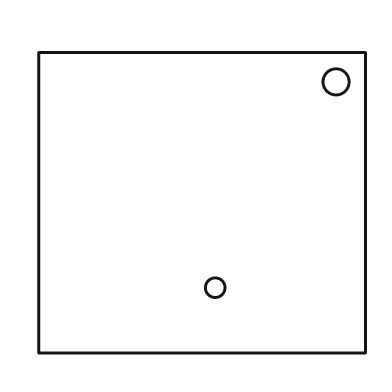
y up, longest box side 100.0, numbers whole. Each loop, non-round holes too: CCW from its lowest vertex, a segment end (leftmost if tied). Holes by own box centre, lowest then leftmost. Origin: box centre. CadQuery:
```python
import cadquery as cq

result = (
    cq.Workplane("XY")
    .moveTo(-50.0, -46.0)
    .lineTo(50.0, -46.0)
    .lineTo(50.0, 46.0)
    .lineTo(-50.0, 46.0)
    .close()
    .moveTo(4.0, -26.0)
    .circle(3.0)
    .moveTo(41.0, 37.0)
    .circle(4.0)
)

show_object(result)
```